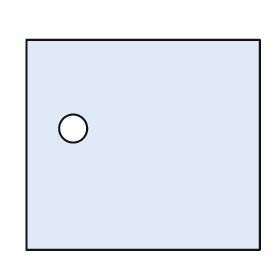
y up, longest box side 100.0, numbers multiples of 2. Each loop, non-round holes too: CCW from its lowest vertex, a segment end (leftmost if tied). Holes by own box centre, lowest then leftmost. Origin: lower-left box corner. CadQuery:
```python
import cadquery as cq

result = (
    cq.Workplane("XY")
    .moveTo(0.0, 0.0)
    .lineTo(100.0, 0.0)
    .lineTo(100.0, 90.0)
    .lineTo(0.0, 90.0)
    .close()
    .moveTo(20.0, 52.0)
    .circle(6.0)
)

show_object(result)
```